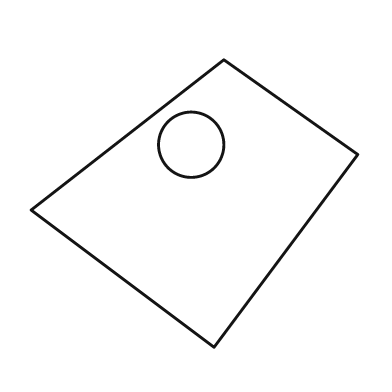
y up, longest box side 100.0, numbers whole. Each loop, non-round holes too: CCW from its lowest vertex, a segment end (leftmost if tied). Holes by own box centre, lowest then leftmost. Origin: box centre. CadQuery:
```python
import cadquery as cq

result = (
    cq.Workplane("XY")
    .moveTo(6.0, -44.0)
    .lineTo(50.0, 15.0)
    .lineTo(9.0, 44.0)
    .lineTo(-50.0, -2.0)
    .close()
    .moveTo(-1.0, 18.0)
    .circle(10.0)
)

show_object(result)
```